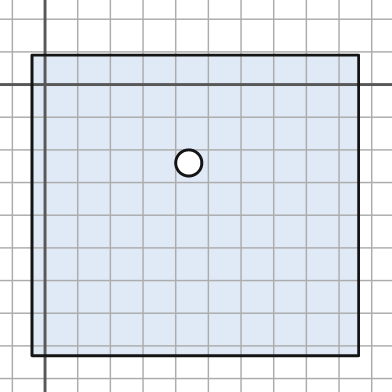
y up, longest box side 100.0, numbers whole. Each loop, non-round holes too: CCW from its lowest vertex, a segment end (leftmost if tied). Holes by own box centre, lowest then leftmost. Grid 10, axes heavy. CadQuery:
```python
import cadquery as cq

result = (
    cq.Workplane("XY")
    .moveTo(-4.0, -83.0)
    .lineTo(96.0, -83.0)
    .lineTo(96.0, 9.0)
    .lineTo(-4.0, 9.0)
    .close()
    .moveTo(44.0, -24.0)
    .circle(4.0)
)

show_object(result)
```